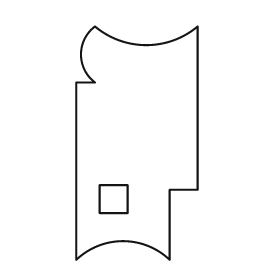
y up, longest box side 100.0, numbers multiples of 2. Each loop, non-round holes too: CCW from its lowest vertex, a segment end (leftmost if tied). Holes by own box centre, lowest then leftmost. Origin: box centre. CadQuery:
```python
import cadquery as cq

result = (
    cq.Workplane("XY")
    .moveTo(-26.0, -50.0)
    .threePointArc((-6.0, -42.0), (14.0, -50.0))
    .lineTo(14.0, -20.0)
    .lineTo(26.0, -20.0)
    .lineTo(26.0, 50.0)
    .threePointArc((4.0, 42.0), (-18.0, 50.0))
    .threePointArc((-24.0, 38.0), (-18.0, 26.0))
    .lineTo(-26.0, 26.0)
    .close()
    .moveTo(-16.0, -30.0)
    .lineTo(-4.0, -30.0)
    .lineTo(-4.0, -18.0)
    .lineTo(-16.0, -18.0)
    .close()
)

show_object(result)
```